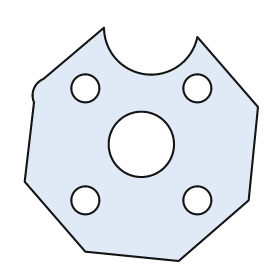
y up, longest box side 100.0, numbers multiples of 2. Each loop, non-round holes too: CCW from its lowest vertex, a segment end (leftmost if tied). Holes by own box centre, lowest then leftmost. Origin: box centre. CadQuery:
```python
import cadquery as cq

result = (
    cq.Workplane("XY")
    .moveTo(16.0, -50.0)
    .lineTo(46.0, -24.0)
    .lineTo(50.0, 16.0)
    .lineTo(24.0, 46.0)
    .threePointArc((2.0, 30.0), (-16.0, 50.0))
    .lineTo(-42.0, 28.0)
    .threePointArc((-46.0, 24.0), (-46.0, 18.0))
    .lineTo(-50.0, -16.0)
    .lineTo(-24.0, -46.0)
    .close()
    .moveTo(-24.0, -24.0)
    .circle(6.0)
    .moveTo(24.0, -24.0)
    .circle(6.0)
    .moveTo(0.0, 0.0)
    .circle(14.0)
    .moveTo(-24.0, 24.0)
    .circle(6.0)
    .moveTo(24.0, 24.0)
    .circle(6.0)
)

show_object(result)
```